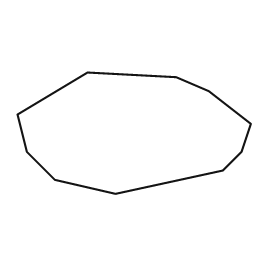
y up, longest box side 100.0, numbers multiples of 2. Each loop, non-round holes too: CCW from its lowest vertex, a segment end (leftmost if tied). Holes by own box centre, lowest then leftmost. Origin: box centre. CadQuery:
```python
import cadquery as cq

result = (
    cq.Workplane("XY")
    .moveTo(-8.0, -26.0)
    .lineTo(38.0, -16.0)
    .lineTo(46.0, -8.0)
    .lineTo(50.0, 4.0)
    .lineTo(32.0, 18.0)
    .lineTo(18.0, 24.0)
    .lineTo(-20.0, 26.0)
    .lineTo(-50.0, 8.0)
    .lineTo(-46.0, -8.0)
    .lineTo(-34.0, -20.0)
    .close()
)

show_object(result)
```